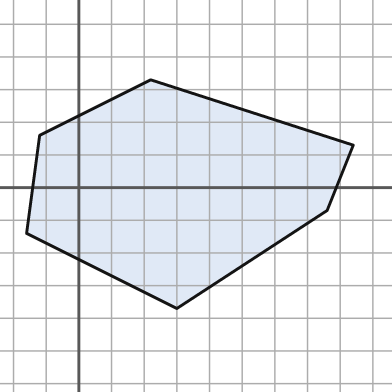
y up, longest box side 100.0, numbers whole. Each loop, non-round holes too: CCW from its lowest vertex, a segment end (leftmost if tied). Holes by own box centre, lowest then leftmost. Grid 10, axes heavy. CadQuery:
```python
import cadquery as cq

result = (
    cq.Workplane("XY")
    .moveTo(30.0, -37.0)
    .lineTo(76.0, -7.0)
    .lineTo(84.0, 13.0)
    .lineTo(22.0, 33.0)
    .lineTo(-12.0, 16.0)
    .lineTo(-16.0, -14.0)
    .close()
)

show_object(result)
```